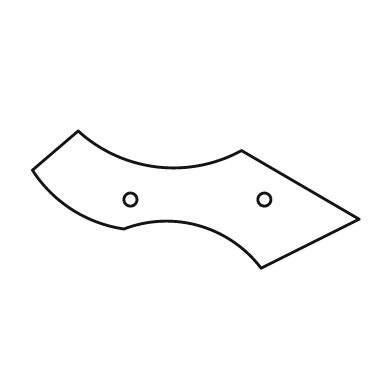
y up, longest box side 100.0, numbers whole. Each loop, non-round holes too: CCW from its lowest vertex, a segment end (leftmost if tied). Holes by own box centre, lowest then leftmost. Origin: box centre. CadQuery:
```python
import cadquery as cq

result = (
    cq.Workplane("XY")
    .moveTo(20.0, -21.0)
    .lineTo(50.0, -6.0)
    .lineTo(14.0, 15.0)
    .threePointArc((-12.0, 10.0), (-36.0, 21.0))
    .lineTo(-50.0, 9.0)
    .threePointArc((-38.0, -3.0), (-22.0, -9.0))
    .threePointArc((1.0, -8.0), (20.0, -21.0))
    .close()
    .moveTo(-20.0, 0.0)
    .circle(2.0)
    .moveTo(21.0, 0.0)
    .circle(2.0)
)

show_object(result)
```